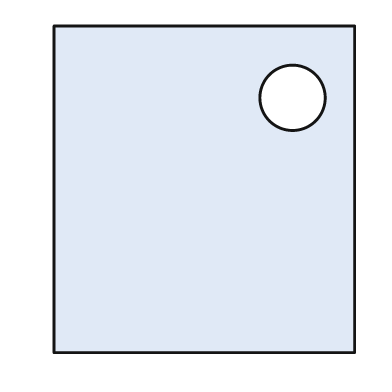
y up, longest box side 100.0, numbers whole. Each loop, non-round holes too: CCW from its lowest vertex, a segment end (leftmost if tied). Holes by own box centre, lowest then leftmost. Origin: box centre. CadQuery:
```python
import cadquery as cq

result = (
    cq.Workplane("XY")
    .moveTo(-46.0, -50.0)
    .lineTo(46.0, -50.0)
    .lineTo(46.0, 50.0)
    .lineTo(-46.0, 50.0)
    .close()
    .moveTo(27.0, 28.0)
    .circle(10.0)
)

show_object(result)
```